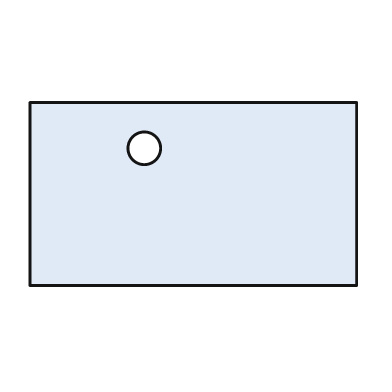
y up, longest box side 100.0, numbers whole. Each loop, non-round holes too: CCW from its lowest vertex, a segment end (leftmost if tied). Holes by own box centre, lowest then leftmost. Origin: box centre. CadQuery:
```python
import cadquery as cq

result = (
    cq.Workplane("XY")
    .moveTo(-50.0, -28.0)
    .lineTo(50.0, -28.0)
    .lineTo(50.0, 28.0)
    .lineTo(-50.0, 28.0)
    .close()
    .moveTo(-15.0, 14.0)
    .circle(5.0)
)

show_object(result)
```